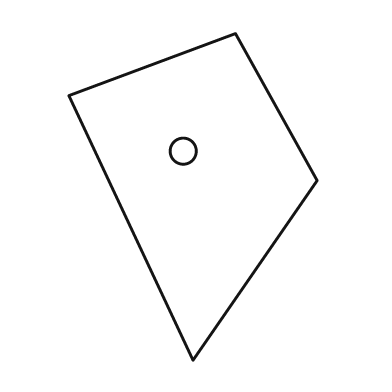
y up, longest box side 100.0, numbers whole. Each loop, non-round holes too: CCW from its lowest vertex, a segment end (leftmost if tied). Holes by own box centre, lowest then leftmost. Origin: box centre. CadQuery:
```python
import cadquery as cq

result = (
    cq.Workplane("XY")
    .moveTo(0.0, -50.0)
    .lineTo(38.0, 5.0)
    .lineTo(13.0, 50.0)
    .lineTo(-38.0, 31.0)
    .close()
    .moveTo(-3.0, 14.0)
    .circle(4.0)
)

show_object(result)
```